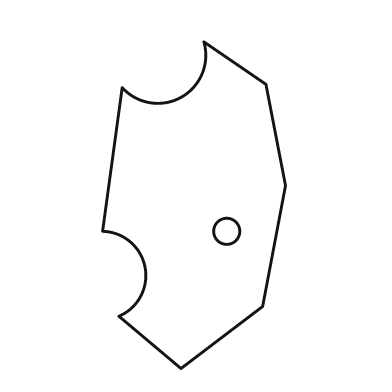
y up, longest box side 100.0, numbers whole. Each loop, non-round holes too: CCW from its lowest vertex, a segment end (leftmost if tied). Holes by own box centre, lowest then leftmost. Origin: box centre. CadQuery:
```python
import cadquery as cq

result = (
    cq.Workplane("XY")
    .moveTo(-4.0, -50.0)
    .lineTo(21.0, -31.0)
    .lineTo(28.0, 6.0)
    .lineTo(22.0, 37.0)
    .lineTo(3.0, 50.0)
    .threePointArc((-4.0, 33.0), (-22.0, 36.0))
    .lineTo(-28.0, -8.0)
    .threePointArc((-15.0, -19.0), (-23.0, -34.0))
    .close()
    .moveTo(10.0, -8.0)
    .circle(4.0)
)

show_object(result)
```